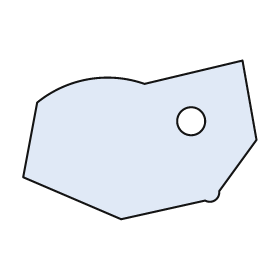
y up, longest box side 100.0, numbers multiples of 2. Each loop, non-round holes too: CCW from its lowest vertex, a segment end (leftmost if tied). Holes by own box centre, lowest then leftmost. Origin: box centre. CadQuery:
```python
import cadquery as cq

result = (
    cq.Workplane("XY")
    .moveTo(-8.0, -34.0)
    .lineTo(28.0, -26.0)
    .threePointArc((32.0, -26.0), (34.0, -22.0))
    .lineTo(50.0, 0.0)
    .lineTo(44.0, 34.0)
    .lineTo(2.0, 24.0)
    .threePointArc((-22.0, 26.0), (-44.0, 16.0))
    .lineTo(-50.0, -16.0)
    .close()
    .moveTo(22.0, 8.0)
    .circle(6.0)
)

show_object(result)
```